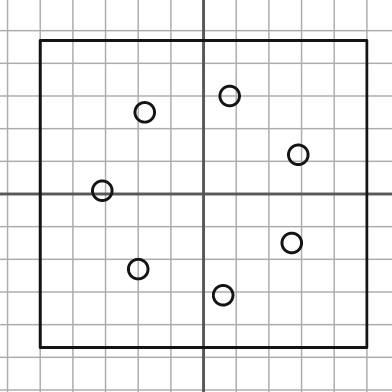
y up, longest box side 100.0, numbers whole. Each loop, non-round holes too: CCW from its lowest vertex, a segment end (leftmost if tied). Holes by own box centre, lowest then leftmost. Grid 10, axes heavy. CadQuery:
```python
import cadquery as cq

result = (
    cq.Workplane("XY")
    .moveTo(-50.0, -47.0)
    .lineTo(50.0, -47.0)
    .lineTo(50.0, 47.0)
    .lineTo(-50.0, 47.0)
    .close()
    .moveTo(6.0, -31.0)
    .circle(3.0)
    .moveTo(-20.0, -23.0)
    .circle(3.0)
    .moveTo(27.0, -15.0)
    .circle(3.0)
    .moveTo(-31.0, 1.0)
    .circle(3.0)
    .moveTo(29.0, 12.0)
    .circle(3.0)
    .moveTo(-18.0, 25.0)
    .circle(3.0)
    .moveTo(8.0, 30.0)
    .circle(3.0)
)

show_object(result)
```